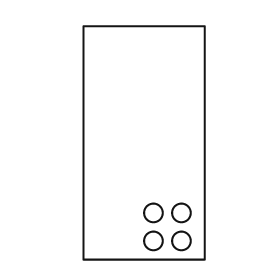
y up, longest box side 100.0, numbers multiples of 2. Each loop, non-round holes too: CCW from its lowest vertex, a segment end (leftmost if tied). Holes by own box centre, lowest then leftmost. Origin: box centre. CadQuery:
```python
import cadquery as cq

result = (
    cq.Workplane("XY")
    .moveTo(-26.0, -50.0)
    .lineTo(26.0, -50.0)
    .lineTo(26.0, 50.0)
    .lineTo(-26.0, 50.0)
    .close()
    .moveTo(4.0, -42.0)
    .circle(4.0)
    .moveTo(16.0, -42.0)
    .circle(4.0)
    .moveTo(4.0, -30.0)
    .circle(4.0)
    .moveTo(16.0, -30.0)
    .circle(4.0)
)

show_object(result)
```